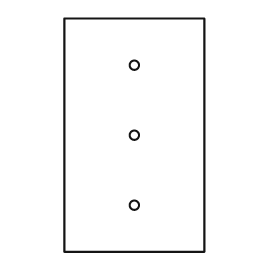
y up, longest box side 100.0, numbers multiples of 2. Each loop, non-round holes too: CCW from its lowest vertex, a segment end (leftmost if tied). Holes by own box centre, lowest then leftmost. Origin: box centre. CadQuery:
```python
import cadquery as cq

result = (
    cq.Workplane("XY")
    .moveTo(-30.0, -50.0)
    .lineTo(30.0, -50.0)
    .lineTo(30.0, 50.0)
    .lineTo(-30.0, 50.0)
    .close()
    .moveTo(0.0, -30.0)
    .circle(2.0)
    .moveTo(0.0, 0.0)
    .circle(2.0)
    .moveTo(0.0, 30.0)
    .circle(2.0)
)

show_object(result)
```